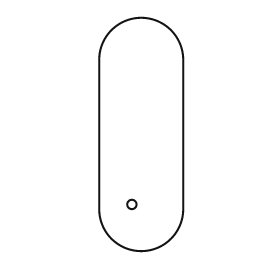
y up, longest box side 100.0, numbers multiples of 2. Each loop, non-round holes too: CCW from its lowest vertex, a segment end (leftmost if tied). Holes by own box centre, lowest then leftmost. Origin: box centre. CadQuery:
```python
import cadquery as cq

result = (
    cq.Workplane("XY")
    .moveTo(-18.0, -32.0)
    .threePointArc((0.0, -50.0), (18.0, -32.0))
    .lineTo(18.0, 32.0)
    .threePointArc((0.0, 50.0), (-18.0, 32.0))
    .close()
    .moveTo(-4.0, -30.0)
    .circle(2.0)
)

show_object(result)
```